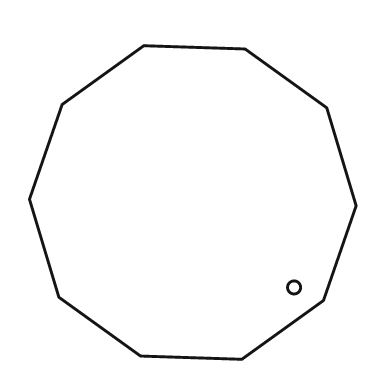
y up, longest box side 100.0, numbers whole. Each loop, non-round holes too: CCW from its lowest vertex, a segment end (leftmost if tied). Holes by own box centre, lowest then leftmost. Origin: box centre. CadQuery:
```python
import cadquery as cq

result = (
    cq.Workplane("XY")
    .moveTo(15.0, -48.0)
    .lineTo(40.0, -30.0)
    .lineTo(50.0, -1.0)
    .lineTo(41.0, 29.0)
    .lineTo(16.0, 47.0)
    .lineTo(-15.0, 48.0)
    .lineTo(-40.0, 30.0)
    .lineTo(-50.0, 1.0)
    .lineTo(-41.0, -29.0)
    .lineTo(-16.0, -47.0)
    .close()
    .moveTo(31.0, -26.0)
    .circle(2.0)
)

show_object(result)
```